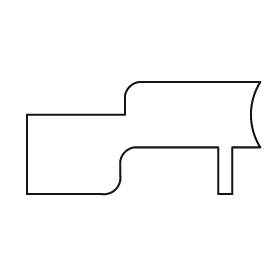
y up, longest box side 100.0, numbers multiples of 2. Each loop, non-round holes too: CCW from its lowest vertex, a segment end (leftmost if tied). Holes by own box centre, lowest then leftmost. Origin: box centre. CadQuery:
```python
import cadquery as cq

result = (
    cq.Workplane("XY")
    .moveTo(-50.0, -24.0)
    .lineTo(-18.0, -24.0)
    .threePointArc((-12.0, -22.0), (-10.0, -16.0))
    .lineTo(-10.0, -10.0)
    .threePointArc((-8.0, -6.0), (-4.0, -4.0))
    .lineTo(32.0, -4.0)
    .lineTo(32.0, -24.0)
    .lineTo(38.0, -24.0)
    .lineTo(38.0, -4.0)
    .lineTo(50.0, -4.0)
    .threePointArc((46.0, 10.0), (50.0, 24.0))
    .lineTo(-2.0, 24.0)
    .threePointArc((-6.0, 22.0), (-8.0, 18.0))
    .lineTo(-8.0, 10.0)
    .lineTo(-50.0, 10.0)
    .close()
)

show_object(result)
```